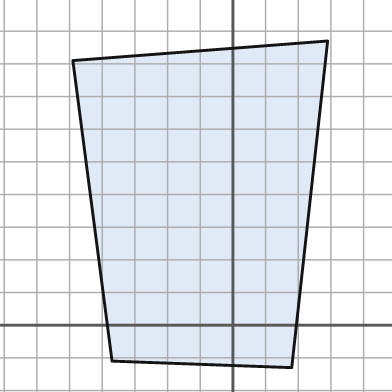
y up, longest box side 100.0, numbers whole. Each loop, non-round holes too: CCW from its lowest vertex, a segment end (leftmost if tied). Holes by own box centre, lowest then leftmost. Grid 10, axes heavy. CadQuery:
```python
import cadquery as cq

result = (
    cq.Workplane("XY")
    .moveTo(18.0, -13.0)
    .lineTo(29.0, 87.0)
    .lineTo(-49.0, 81.0)
    .lineTo(-37.0, -11.0)
    .close()
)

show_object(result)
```